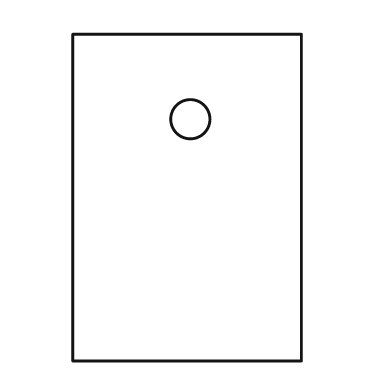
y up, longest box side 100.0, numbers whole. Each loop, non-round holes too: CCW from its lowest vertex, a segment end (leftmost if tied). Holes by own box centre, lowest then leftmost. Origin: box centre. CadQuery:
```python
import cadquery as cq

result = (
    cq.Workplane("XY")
    .moveTo(-35.0, -50.0)
    .lineTo(35.0, -50.0)
    .lineTo(35.0, 50.0)
    .lineTo(-35.0, 50.0)
    .close()
    .moveTo(1.0, 24.0)
    .circle(6.0)
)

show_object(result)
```